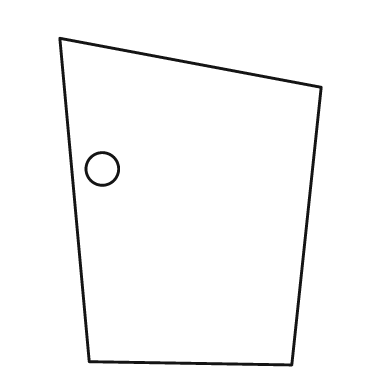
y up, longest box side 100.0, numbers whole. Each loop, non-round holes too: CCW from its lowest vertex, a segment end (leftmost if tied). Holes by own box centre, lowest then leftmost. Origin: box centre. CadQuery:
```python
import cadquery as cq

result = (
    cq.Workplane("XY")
    .moveTo(31.0, -50.0)
    .lineTo(40.0, 35.0)
    .lineTo(-40.0, 50.0)
    .lineTo(-31.0, -49.0)
    .close()
    .moveTo(-27.0, 10.0)
    .circle(5.0)
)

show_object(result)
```